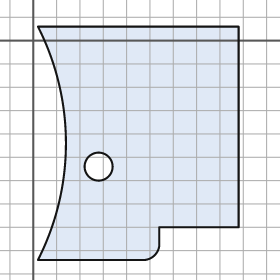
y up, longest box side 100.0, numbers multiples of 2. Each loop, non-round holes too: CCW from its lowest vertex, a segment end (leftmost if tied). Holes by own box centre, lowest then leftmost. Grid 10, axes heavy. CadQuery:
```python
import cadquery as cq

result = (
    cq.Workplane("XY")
    .moveTo(2.0, -94.0)
    .lineTo(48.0, -94.0)
    .threePointArc((52.0, -92.0), (54.0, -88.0))
    .lineTo(54.0, -80.0)
    .lineTo(88.0, -80.0)
    .lineTo(88.0, 6.0)
    .lineTo(2.0, 6.0)
    .threePointArc((14.0, -44.0), (2.0, -94.0))
    .close()
    .moveTo(28.0, -54.0)
    .circle(6.0)
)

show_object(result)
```